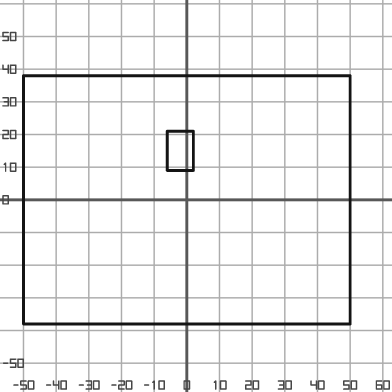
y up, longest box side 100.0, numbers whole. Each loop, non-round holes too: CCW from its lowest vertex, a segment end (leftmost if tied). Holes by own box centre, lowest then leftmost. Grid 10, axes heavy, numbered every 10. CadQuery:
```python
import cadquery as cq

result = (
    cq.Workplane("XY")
    .moveTo(-50.0, -38.0)
    .lineTo(50.0, -38.0)
    .lineTo(50.0, 38.0)
    .lineTo(-50.0, 38.0)
    .close()
    .moveTo(-6.0, 9.0)
    .lineTo(2.0, 9.0)
    .lineTo(2.0, 21.0)
    .lineTo(-6.0, 21.0)
    .close()
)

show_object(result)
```